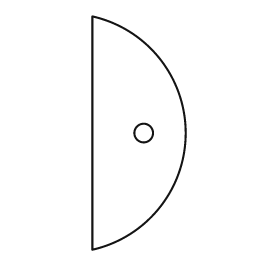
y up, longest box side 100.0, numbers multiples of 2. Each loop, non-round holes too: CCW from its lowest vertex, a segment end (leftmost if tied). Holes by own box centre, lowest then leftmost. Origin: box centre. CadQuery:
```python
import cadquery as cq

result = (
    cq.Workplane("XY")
    .moveTo(-20.0, -50.0)
    .threePointArc((20.0, 0.0), (-20.0, 50.0))
    .close()
    .moveTo(2.0, 0.0)
    .circle(4.0)
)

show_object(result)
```